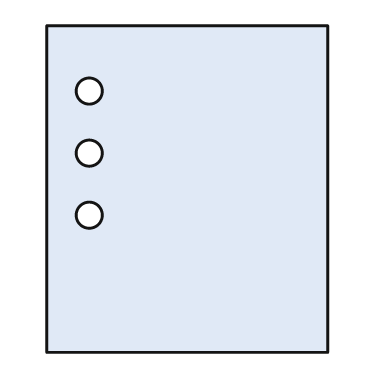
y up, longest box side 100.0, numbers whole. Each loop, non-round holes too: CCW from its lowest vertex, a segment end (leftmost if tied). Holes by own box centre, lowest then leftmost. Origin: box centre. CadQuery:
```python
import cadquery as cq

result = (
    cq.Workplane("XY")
    .moveTo(-43.0, -50.0)
    .lineTo(43.0, -50.0)
    .lineTo(43.0, 50.0)
    .lineTo(-43.0, 50.0)
    .close()
    .moveTo(-30.0, -8.0)
    .circle(4.0)
    .moveTo(-30.0, 11.0)
    .circle(4.0)
    .moveTo(-30.0, 30.0)
    .circle(4.0)
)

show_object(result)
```